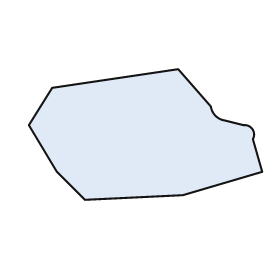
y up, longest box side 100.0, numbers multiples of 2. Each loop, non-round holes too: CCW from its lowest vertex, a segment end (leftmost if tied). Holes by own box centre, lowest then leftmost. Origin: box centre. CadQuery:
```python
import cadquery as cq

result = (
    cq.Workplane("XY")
    .moveTo(-26.0, -28.0)
    .lineTo(16.0, -26.0)
    .lineTo(50.0, -16.0)
    .lineTo(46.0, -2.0)
    .threePointArc((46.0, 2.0), (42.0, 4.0))
    .lineTo(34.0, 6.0)
    .threePointArc((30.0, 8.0), (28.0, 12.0))
    .lineTo(14.0, 28.0)
    .lineTo(-40.0, 20.0)
    .lineTo(-50.0, 4.0)
    .lineTo(-38.0, -16.0)
    .close()
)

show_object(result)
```